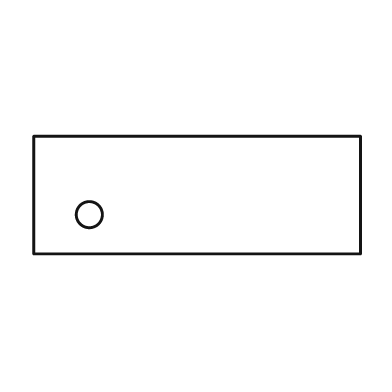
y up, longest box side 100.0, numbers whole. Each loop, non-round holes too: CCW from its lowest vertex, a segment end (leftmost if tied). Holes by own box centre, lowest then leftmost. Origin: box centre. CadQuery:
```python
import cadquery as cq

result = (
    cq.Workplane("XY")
    .moveTo(-50.0, -18.0)
    .lineTo(50.0, -18.0)
    .lineTo(50.0, 18.0)
    .lineTo(-50.0, 18.0)
    .close()
    .moveTo(-33.0, -6.0)
    .circle(4.0)
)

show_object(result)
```